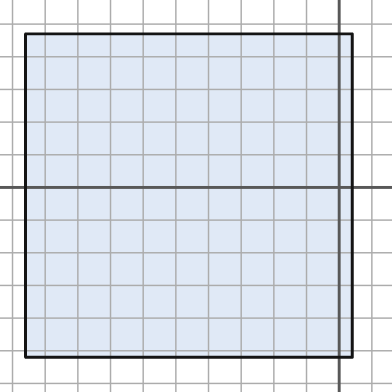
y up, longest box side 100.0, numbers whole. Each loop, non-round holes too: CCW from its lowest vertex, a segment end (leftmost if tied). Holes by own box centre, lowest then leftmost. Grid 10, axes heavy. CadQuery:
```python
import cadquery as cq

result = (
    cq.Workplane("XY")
    .moveTo(-96.0, -52.0)
    .lineTo(4.0, -52.0)
    .lineTo(4.0, 47.0)
    .lineTo(-96.0, 47.0)
    .close()
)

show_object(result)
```